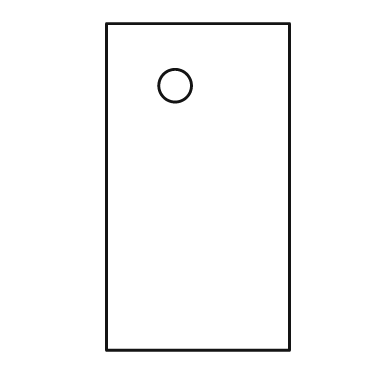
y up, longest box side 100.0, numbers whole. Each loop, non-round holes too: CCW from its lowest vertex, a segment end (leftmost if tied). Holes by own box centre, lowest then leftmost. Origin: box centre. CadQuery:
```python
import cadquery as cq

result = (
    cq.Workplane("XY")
    .moveTo(-28.0, -50.0)
    .lineTo(28.0, -50.0)
    .lineTo(28.0, 50.0)
    .lineTo(-28.0, 50.0)
    .close()
    .moveTo(-7.0, 31.0)
    .circle(5.0)
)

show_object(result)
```